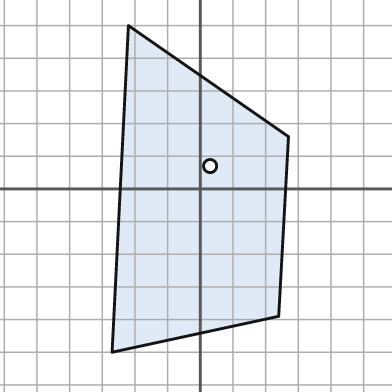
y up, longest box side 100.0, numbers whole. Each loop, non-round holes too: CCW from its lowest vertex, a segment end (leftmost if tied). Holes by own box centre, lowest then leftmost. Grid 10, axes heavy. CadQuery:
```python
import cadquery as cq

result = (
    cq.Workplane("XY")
    .moveTo(-27.0, -50.0)
    .lineTo(24.0, -39.0)
    .lineTo(27.0, 16.0)
    .lineTo(-22.0, 50.0)
    .close()
    .moveTo(3.0, 7.0)
    .circle(2.0)
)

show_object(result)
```